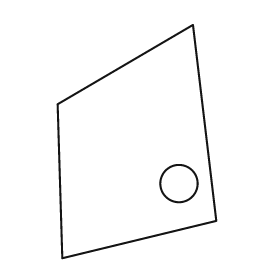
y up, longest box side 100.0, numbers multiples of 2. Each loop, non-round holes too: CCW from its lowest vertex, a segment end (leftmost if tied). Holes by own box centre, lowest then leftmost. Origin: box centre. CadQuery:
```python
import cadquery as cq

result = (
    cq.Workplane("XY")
    .moveTo(-32.0, -50.0)
    .lineTo(34.0, -34.0)
    .lineTo(24.0, 50.0)
    .lineTo(-34.0, 16.0)
    .close()
    .moveTo(18.0, -18.0)
    .circle(8.0)
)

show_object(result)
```